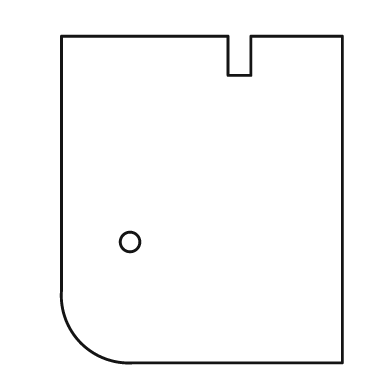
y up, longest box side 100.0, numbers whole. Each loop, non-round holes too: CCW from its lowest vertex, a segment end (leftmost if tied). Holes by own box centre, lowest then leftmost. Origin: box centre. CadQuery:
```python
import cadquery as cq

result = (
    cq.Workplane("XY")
    .moveTo(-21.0, -50.0)
    .lineTo(43.0, -50.0)
    .lineTo(43.0, 50.0)
    .lineTo(15.0, 50.0)
    .lineTo(15.0, 38.0)
    .lineTo(8.0, 38.0)
    .lineTo(8.0, 50.0)
    .lineTo(-43.0, 50.0)
    .lineTo(-43.0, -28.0)
    .threePointArc((-37.0, -44.0), (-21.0, -50.0))
    .close()
    .moveTo(-22.0, -13.0)
    .circle(3.0)
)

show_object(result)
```